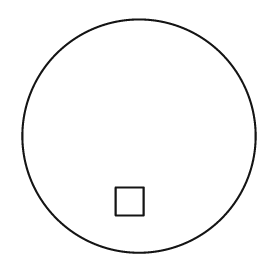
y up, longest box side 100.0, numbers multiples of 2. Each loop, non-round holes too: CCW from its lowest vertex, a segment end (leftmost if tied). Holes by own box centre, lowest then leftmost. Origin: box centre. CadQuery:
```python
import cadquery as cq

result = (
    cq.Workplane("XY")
    .moveTo(0.0, 0.0)
    .circle(50.0)
    .moveTo(-10.0, -34.0)
    .lineTo(2.0, -34.0)
    .lineTo(2.0, -22.0)
    .lineTo(-10.0, -22.0)
    .close()
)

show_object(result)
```